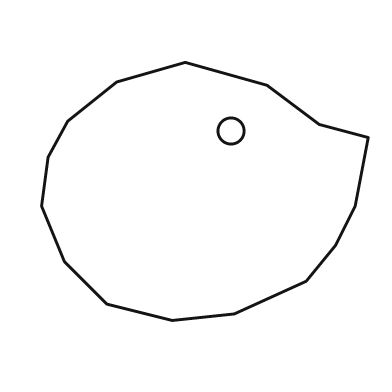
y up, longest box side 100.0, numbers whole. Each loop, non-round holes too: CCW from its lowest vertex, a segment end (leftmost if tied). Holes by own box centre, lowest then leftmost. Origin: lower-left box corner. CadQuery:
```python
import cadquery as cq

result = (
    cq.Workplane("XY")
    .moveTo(40.0, 0.0)
    .lineTo(59.0, 2.0)
    .lineTo(81.0, 12.0)
    .lineTo(90.0, 23.0)
    .lineTo(96.0, 35.0)
    .lineTo(100.0, 56.0)
    .lineTo(85.0, 60.0)
    .lineTo(69.0, 72.0)
    .lineTo(44.0, 79.0)
    .lineTo(23.0, 73.0)
    .lineTo(8.0, 61.0)
    .lineTo(2.0, 50.0)
    .lineTo(0.0, 35.0)
    .lineTo(7.0, 18.0)
    .lineTo(20.0, 5.0)
    .close()
    .moveTo(58.0, 58.0)
    .circle(4.0)
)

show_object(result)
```